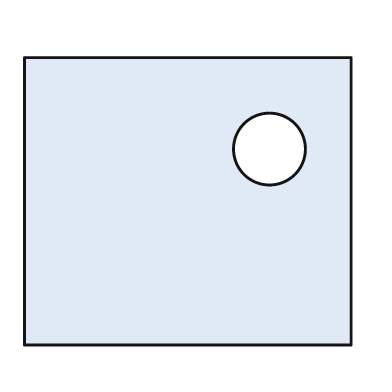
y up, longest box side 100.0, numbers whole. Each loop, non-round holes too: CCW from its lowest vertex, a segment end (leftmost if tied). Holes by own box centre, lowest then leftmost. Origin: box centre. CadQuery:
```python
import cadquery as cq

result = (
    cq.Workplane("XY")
    .moveTo(-50.0, -44.0)
    .lineTo(50.0, -44.0)
    .lineTo(50.0, 44.0)
    .lineTo(-50.0, 44.0)
    .close()
    .moveTo(25.0, 16.0)
    .circle(11.0)
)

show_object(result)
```